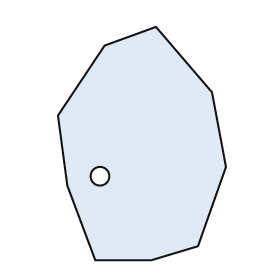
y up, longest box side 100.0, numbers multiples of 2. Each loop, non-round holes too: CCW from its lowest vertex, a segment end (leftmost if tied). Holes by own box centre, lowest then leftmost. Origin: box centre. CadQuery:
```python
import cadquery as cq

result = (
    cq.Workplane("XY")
    .moveTo(-20.0, -50.0)
    .lineTo(4.0, -50.0)
    .lineTo(24.0, -44.0)
    .lineTo(36.0, -10.0)
    .lineTo(30.0, 22.0)
    .lineTo(6.0, 50.0)
    .lineTo(-16.0, 42.0)
    .lineTo(-36.0, 12.0)
    .lineTo(-32.0, -18.0)
    .close()
    .moveTo(-18.0, -14.0)
    .circle(4.0)
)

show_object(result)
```